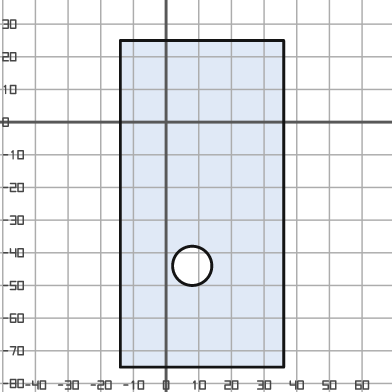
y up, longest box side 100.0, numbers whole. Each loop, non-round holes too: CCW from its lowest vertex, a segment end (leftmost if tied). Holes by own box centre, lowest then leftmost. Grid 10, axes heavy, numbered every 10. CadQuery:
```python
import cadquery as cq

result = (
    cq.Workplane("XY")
    .moveTo(-14.0, -75.0)
    .lineTo(36.0, -75.0)
    .lineTo(36.0, 25.0)
    .lineTo(-14.0, 25.0)
    .close()
    .moveTo(8.0, -44.0)
    .circle(6.0)
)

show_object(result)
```